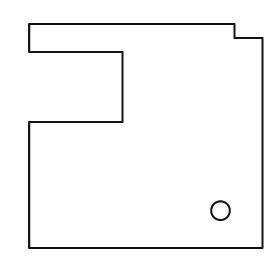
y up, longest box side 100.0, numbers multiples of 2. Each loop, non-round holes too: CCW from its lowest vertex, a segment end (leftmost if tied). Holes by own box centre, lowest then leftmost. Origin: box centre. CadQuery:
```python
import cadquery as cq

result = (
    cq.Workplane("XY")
    .moveTo(-50.0, -48.0)
    .lineTo(50.0, -48.0)
    .lineTo(50.0, 42.0)
    .lineTo(38.0, 42.0)
    .lineTo(38.0, 48.0)
    .lineTo(-50.0, 48.0)
    .lineTo(-50.0, 36.0)
    .lineTo(-10.0, 36.0)
    .lineTo(-10.0, 6.0)
    .lineTo(-50.0, 6.0)
    .close()
    .moveTo(32.0, -32.0)
    .circle(4.0)
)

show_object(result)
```